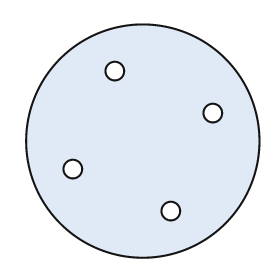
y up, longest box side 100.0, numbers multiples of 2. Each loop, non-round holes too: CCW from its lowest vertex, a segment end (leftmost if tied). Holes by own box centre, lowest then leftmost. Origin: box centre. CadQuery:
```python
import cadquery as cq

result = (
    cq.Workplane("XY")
    .moveTo(0.0, 0.0)
    .circle(50.0)
    .moveTo(12.0, -30.0)
    .circle(4.0)
    .moveTo(-30.0, -12.0)
    .circle(4.0)
    .moveTo(30.0, 12.0)
    .circle(4.0)
    .moveTo(-12.0, 30.0)
    .circle(4.0)
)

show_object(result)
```